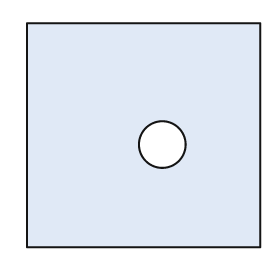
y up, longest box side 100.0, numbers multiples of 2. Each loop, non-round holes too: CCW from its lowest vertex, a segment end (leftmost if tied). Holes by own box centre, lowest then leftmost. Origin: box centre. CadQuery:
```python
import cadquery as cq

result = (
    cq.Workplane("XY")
    .moveTo(-50.0, -48.0)
    .lineTo(50.0, -48.0)
    .lineTo(50.0, 48.0)
    .lineTo(-50.0, 48.0)
    .close()
    .moveTo(8.0, -4.0)
    .circle(10.0)
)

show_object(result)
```